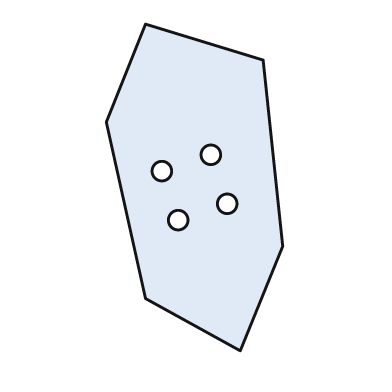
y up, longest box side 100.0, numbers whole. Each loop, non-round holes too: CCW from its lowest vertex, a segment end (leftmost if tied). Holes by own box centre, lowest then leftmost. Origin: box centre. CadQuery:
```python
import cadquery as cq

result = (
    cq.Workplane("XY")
    .moveTo(14.0, -50.0)
    .lineTo(27.0, -18.0)
    .lineTo(21.0, 39.0)
    .lineTo(-15.0, 50.0)
    .lineTo(-27.0, 20.0)
    .lineTo(-15.0, -34.0)
    .close()
    .moveTo(-5.0, -10.0)
    .circle(3.0)
    .moveTo(10.0, -5.0)
    .circle(3.0)
    .moveTo(-10.0, 5.0)
    .circle(3.0)
    .moveTo(5.0, 10.0)
    .circle(3.0)
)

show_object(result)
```